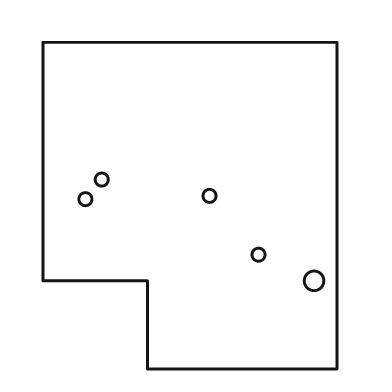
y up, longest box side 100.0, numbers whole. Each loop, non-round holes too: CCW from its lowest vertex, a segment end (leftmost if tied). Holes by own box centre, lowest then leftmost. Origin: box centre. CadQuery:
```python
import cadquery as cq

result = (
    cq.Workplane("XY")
    .moveTo(-13.0, -50.0)
    .lineTo(45.0, -50.0)
    .lineTo(45.0, 50.0)
    .lineTo(-45.0, 50.0)
    .lineTo(-45.0, -23.0)
    .lineTo(-13.0, -23.0)
    .close()
    .moveTo(38.0, -23.0)
    .circle(3.0)
    .moveTo(21.0, -15.0)
    .circle(2.0)
    .moveTo(-32.0, 2.0)
    .circle(2.0)
    .moveTo(6.0, 3.0)
    .circle(2.0)
    .moveTo(-27.0, 8.0)
    .circle(2.0)
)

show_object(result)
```